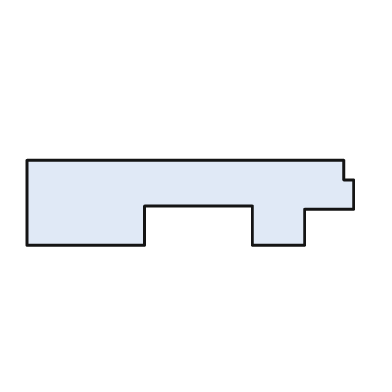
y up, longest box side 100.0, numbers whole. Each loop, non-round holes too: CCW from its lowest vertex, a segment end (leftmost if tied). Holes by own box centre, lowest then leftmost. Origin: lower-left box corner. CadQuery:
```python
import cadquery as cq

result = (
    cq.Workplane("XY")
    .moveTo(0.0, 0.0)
    .lineTo(36.0, 0.0)
    .lineTo(36.0, 12.0)
    .lineTo(69.0, 12.0)
    .lineTo(69.0, 0.0)
    .lineTo(85.0, 0.0)
    .lineTo(85.0, 11.0)
    .lineTo(100.0, 11.0)
    .lineTo(100.0, 20.0)
    .lineTo(97.0, 20.0)
    .lineTo(97.0, 26.0)
    .lineTo(0.0, 26.0)
    .close()
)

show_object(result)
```